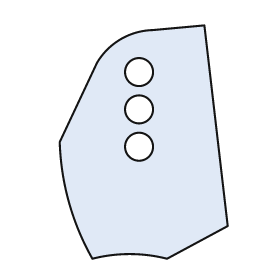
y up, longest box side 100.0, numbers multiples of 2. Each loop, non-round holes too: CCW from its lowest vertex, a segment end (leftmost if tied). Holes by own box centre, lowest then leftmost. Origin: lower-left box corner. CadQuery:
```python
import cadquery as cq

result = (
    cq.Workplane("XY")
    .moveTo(14.0, 0.0)
    .threePointArc((30.0, 2.0), (46.0, 0.0))
    .lineTo(72.0, 14.0)
    .lineTo(62.0, 100.0)
    .lineTo(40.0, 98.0)
    .threePointArc((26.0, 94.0), (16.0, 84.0))
    .lineTo(0.0, 50.0)
    .threePointArc((4.0, 24.0), (14.0, 0.0))
    .close()
    .moveTo(34.0, 48.0)
    .circle(6.0)
    .moveTo(34.0, 64.0)
    .circle(6.0)
    .moveTo(34.0, 80.0)
    .circle(6.0)
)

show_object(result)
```